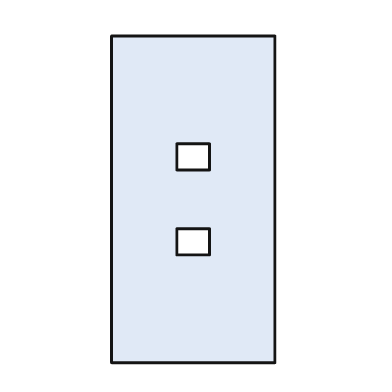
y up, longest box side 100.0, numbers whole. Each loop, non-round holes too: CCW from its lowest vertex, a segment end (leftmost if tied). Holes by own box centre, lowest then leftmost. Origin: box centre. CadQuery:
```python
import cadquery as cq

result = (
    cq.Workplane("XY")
    .moveTo(-25.0, -50.0)
    .lineTo(25.0, -50.0)
    .lineTo(25.0, 50.0)
    .lineTo(-25.0, 50.0)
    .close()
    .moveTo(-5.0, -17.0)
    .lineTo(5.0, -17.0)
    .lineTo(5.0, -9.0)
    .lineTo(-5.0, -9.0)
    .close()
    .moveTo(-5.0, 9.0)
    .lineTo(5.0, 9.0)
    .lineTo(5.0, 17.0)
    .lineTo(-5.0, 17.0)
    .close()
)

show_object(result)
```